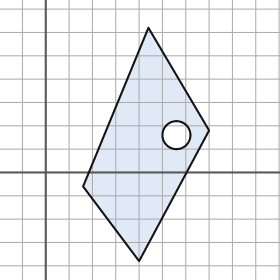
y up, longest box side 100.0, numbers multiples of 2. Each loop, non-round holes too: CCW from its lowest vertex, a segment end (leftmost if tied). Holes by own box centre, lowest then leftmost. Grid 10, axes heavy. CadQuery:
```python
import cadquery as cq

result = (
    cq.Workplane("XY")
    .moveTo(40.0, -38.0)
    .lineTo(70.0, 18.0)
    .lineTo(44.0, 62.0)
    .lineTo(16.0, -6.0)
    .close()
    .moveTo(56.0, 16.0)
    .circle(6.0)
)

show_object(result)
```